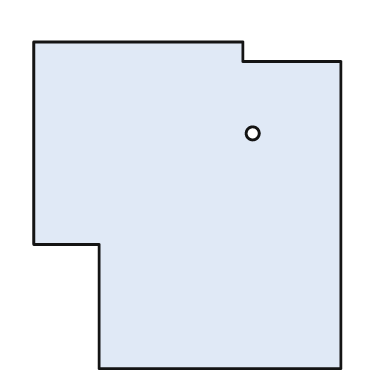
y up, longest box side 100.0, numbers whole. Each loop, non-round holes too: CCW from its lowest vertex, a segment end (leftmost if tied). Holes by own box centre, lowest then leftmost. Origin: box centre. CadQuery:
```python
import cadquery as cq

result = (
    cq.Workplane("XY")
    .moveTo(-27.0, -50.0)
    .lineTo(47.0, -50.0)
    .lineTo(47.0, 44.0)
    .lineTo(17.0, 44.0)
    .lineTo(17.0, 50.0)
    .lineTo(-47.0, 50.0)
    .lineTo(-47.0, -12.0)
    .lineTo(-27.0, -12.0)
    .close()
    .moveTo(20.0, 22.0)
    .circle(2.0)
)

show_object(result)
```